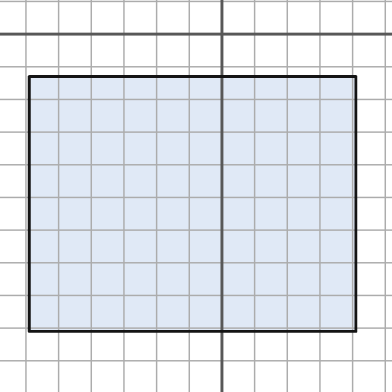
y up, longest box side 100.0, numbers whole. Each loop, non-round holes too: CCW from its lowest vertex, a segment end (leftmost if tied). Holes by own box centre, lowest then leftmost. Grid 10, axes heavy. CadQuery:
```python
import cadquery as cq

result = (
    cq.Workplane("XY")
    .moveTo(-59.0, -91.0)
    .lineTo(41.0, -91.0)
    .lineTo(41.0, -13.0)
    .lineTo(-59.0, -13.0)
    .close()
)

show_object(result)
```